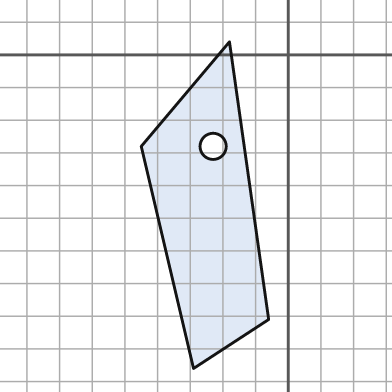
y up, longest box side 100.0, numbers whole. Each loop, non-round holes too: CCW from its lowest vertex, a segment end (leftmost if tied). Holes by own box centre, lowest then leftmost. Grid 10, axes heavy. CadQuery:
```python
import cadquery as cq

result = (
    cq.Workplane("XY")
    .moveTo(-29.0, -96.0)
    .lineTo(-6.0, -81.0)
    .lineTo(-18.0, 4.0)
    .lineTo(-45.0, -28.0)
    .close()
    .moveTo(-23.0, -28.0)
    .circle(4.0)
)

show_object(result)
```